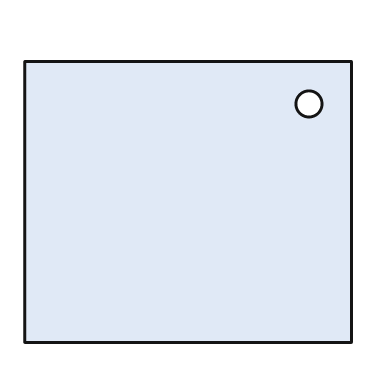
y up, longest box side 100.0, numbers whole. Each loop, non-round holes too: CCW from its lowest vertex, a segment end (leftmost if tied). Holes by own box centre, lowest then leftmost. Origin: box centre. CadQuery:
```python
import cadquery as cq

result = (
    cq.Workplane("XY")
    .moveTo(-50.0, -43.0)
    .lineTo(50.0, -43.0)
    .lineTo(50.0, 43.0)
    .lineTo(-50.0, 43.0)
    .close()
    .moveTo(37.0, 30.0)
    .circle(4.0)
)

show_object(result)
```